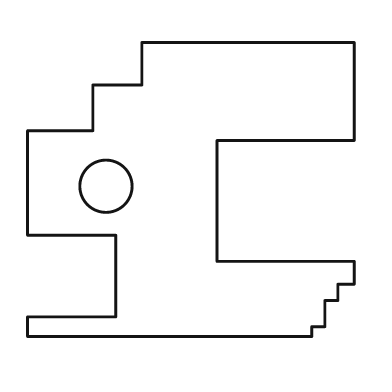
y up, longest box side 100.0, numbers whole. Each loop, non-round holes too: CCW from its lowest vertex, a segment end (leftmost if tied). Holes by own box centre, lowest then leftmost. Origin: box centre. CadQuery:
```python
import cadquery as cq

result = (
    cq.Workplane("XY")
    .moveTo(-50.0, -45.0)
    .lineTo(37.0, -45.0)
    .lineTo(37.0, -42.0)
    .lineTo(41.0, -42.0)
    .lineTo(41.0, -34.0)
    .lineTo(45.0, -34.0)
    .lineTo(45.0, -29.0)
    .lineTo(50.0, -29.0)
    .lineTo(50.0, -22.0)
    .lineTo(8.0, -22.0)
    .lineTo(8.0, 15.0)
    .lineTo(50.0, 15.0)
    .lineTo(50.0, 45.0)
    .lineTo(-15.0, 45.0)
    .lineTo(-15.0, 32.0)
    .lineTo(-30.0, 32.0)
    .lineTo(-30.0, 18.0)
    .lineTo(-50.0, 18.0)
    .lineTo(-50.0, -14.0)
    .lineTo(-23.0, -14.0)
    .lineTo(-23.0, -39.0)
    .lineTo(-50.0, -39.0)
    .close()
    .moveTo(-26.0, 1.0)
    .circle(8.0)
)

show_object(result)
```